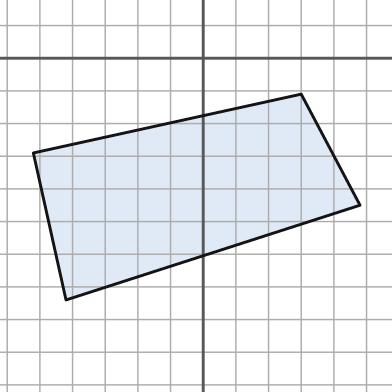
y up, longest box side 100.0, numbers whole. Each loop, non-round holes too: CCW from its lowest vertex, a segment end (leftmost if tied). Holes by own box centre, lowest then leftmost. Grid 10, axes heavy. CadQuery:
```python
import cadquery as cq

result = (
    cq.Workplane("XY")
    .moveTo(-42.0, -74.0)
    .lineTo(48.0, -45.0)
    .lineTo(30.0, -11.0)
    .lineTo(-52.0, -29.0)
    .close()
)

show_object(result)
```